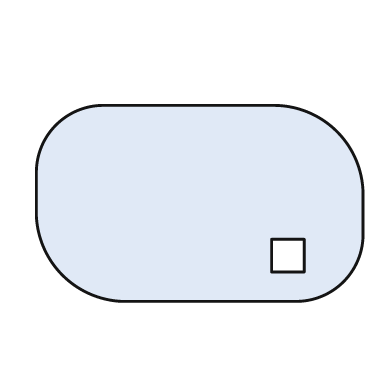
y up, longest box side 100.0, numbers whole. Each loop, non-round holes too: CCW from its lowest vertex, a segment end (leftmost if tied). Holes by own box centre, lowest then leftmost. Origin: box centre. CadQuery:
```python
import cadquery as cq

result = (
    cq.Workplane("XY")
    .moveTo(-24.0, -30.0)
    .lineTo(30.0, -30.0)
    .threePointArc((44.0, -24.0), (50.0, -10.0))
    .lineTo(50.0, 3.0)
    .threePointArc((42.0, 22.0), (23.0, 30.0))
    .lineTo(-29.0, 30.0)
    .threePointArc((-44.0, 24.0), (-50.0, 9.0))
    .lineTo(-50.0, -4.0)
    .threePointArc((-42.0, -22.0), (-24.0, -30.0))
    .close()
    .moveTo(22.0, -21.0)
    .lineTo(32.0, -21.0)
    .lineTo(32.0, -11.0)
    .lineTo(22.0, -11.0)
    .close()
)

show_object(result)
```